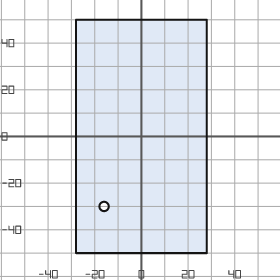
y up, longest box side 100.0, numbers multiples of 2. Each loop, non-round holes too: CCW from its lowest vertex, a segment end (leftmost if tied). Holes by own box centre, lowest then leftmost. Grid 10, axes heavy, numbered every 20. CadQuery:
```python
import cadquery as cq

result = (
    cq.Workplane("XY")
    .moveTo(-28.0, -50.0)
    .lineTo(28.0, -50.0)
    .lineTo(28.0, 50.0)
    .lineTo(-28.0, 50.0)
    .close()
    .moveTo(-16.0, -30.0)
    .circle(2.0)
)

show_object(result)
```